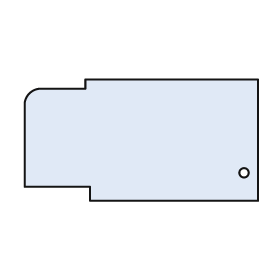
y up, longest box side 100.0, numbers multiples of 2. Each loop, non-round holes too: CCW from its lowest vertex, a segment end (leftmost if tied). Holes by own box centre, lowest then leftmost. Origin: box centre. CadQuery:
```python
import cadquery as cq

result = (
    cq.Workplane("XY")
    .moveTo(-22.0, -26.0)
    .lineTo(50.0, -26.0)
    .lineTo(50.0, 26.0)
    .lineTo(-24.0, 26.0)
    .lineTo(-24.0, 22.0)
    .lineTo(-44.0, 22.0)
    .threePointArc((-48.0, 20.0), (-50.0, 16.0))
    .lineTo(-50.0, -20.0)
    .lineTo(-22.0, -20.0)
    .close()
    .moveTo(44.0, -14.0)
    .circle(2.0)
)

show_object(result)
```